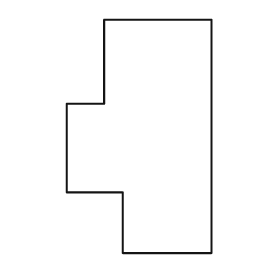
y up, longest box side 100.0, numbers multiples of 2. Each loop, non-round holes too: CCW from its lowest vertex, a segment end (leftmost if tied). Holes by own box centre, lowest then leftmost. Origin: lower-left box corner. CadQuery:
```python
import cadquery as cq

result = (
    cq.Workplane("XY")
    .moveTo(24.0, 0.0)
    .lineTo(62.0, 0.0)
    .lineTo(62.0, 100.0)
    .lineTo(16.0, 100.0)
    .lineTo(16.0, 64.0)
    .lineTo(0.0, 64.0)
    .lineTo(0.0, 26.0)
    .lineTo(24.0, 26.0)
    .close()
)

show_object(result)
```